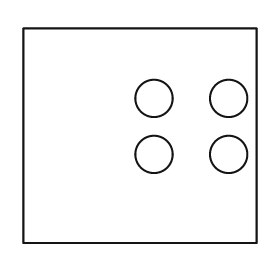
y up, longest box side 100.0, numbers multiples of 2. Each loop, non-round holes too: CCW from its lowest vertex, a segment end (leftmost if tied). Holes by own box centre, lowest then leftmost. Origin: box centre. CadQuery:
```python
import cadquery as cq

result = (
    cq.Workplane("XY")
    .moveTo(-50.0, -46.0)
    .lineTo(50.0, -46.0)
    .lineTo(50.0, 46.0)
    .lineTo(-50.0, 46.0)
    .close()
    .moveTo(6.0, -8.0)
    .circle(8.0)
    .moveTo(38.0, -8.0)
    .circle(8.0)
    .moveTo(6.0, 16.0)
    .circle(8.0)
    .moveTo(38.0, 16.0)
    .circle(8.0)
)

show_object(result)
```